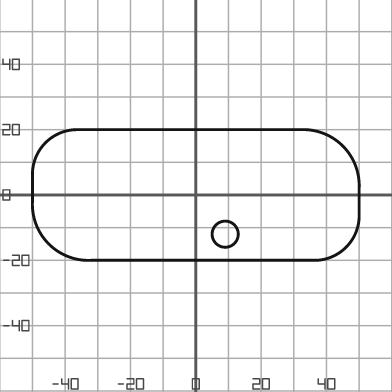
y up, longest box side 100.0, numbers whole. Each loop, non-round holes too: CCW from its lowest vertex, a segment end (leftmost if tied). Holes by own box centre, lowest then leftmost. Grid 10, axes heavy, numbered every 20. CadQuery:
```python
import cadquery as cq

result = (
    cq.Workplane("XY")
    .moveTo(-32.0, -20.0)
    .lineTo(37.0, -20.0)
    .threePointArc((46.0, -16.0), (50.0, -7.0))
    .lineTo(50.0, 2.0)
    .threePointArc((45.0, 15.0), (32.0, 20.0))
    .lineTo(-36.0, 20.0)
    .threePointArc((-46.0, 16.0), (-50.0, 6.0))
    .lineTo(-50.0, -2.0)
    .threePointArc((-45.0, -15.0), (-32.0, -20.0))
    .close()
    .moveTo(9.0, -12.0)
    .circle(4.0)
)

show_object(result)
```